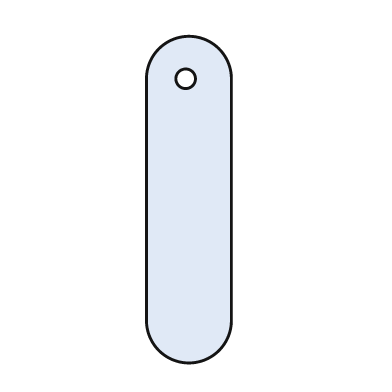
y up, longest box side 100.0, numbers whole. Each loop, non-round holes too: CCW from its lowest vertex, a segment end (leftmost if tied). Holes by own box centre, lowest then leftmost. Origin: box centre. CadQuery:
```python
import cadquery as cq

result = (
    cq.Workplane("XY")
    .moveTo(-13.0, -37.0)
    .threePointArc((0.0, -50.0), (13.0, -37.0))
    .lineTo(13.0, 37.0)
    .threePointArc((0.0, 50.0), (-13.0, 37.0))
    .close()
    .moveTo(-1.0, 37.0)
    .circle(3.0)
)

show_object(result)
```